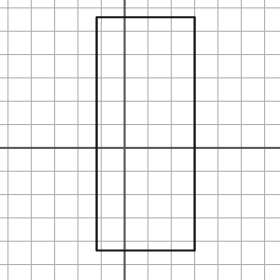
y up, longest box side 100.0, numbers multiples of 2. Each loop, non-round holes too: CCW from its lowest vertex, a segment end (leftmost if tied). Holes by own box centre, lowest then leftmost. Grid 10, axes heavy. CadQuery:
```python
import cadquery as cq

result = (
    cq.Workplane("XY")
    .moveTo(-12.0, -44.0)
    .lineTo(30.0, -44.0)
    .lineTo(30.0, 56.0)
    .lineTo(-12.0, 56.0)
    .close()
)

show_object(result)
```